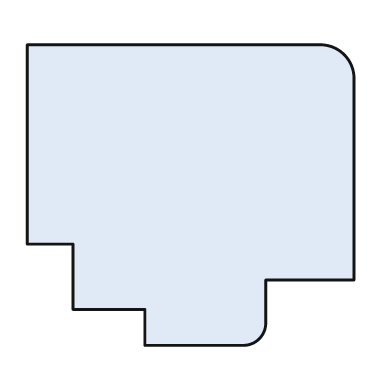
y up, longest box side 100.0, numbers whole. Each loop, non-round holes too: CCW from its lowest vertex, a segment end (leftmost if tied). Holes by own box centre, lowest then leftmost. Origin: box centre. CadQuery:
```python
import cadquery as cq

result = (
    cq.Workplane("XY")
    .moveTo(-14.0, -46.0)
    .lineTo(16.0, -46.0)
    .threePointArc((21.0, -44.0), (23.0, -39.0))
    .lineTo(23.0, -26.0)
    .lineTo(50.0, -26.0)
    .lineTo(50.0, 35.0)
    .threePointArc((47.0, 43.0), (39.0, 46.0))
    .lineTo(-50.0, 46.0)
    .lineTo(-50.0, -15.0)
    .lineTo(-36.0, -15.0)
    .lineTo(-36.0, -35.0)
    .lineTo(-14.0, -35.0)
    .close()
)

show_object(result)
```